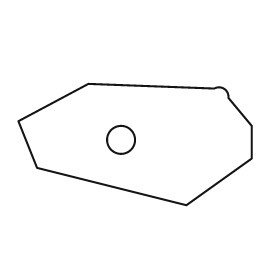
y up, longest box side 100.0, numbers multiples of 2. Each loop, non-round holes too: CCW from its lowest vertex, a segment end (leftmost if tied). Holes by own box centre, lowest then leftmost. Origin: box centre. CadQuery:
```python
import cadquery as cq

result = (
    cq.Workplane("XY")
    .moveTo(22.0, -26.0)
    .lineTo(50.0, -6.0)
    .lineTo(50.0, 8.0)
    .lineTo(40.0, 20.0)
    .threePointArc((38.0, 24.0), (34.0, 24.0))
    .lineTo(-20.0, 26.0)
    .lineTo(-50.0, 10.0)
    .lineTo(-42.0, -10.0)
    .close()
    .moveTo(-6.0, 2.0)
    .circle(6.0)
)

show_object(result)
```